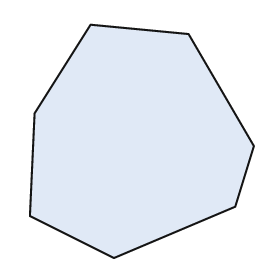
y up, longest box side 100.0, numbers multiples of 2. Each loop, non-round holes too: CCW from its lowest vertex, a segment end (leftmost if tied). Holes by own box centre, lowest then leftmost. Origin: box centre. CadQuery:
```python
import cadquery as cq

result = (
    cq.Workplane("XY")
    .moveTo(-12.0, -50.0)
    .lineTo(40.0, -28.0)
    .lineTo(48.0, -2.0)
    .lineTo(20.0, 46.0)
    .lineTo(-22.0, 50.0)
    .lineTo(-46.0, 12.0)
    .lineTo(-48.0, -32.0)
    .close()
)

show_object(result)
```